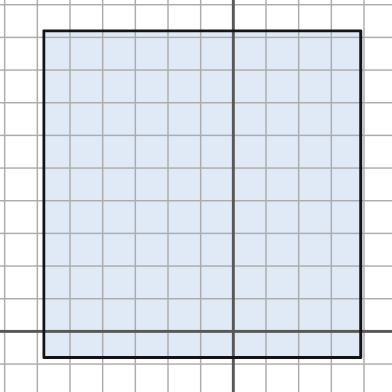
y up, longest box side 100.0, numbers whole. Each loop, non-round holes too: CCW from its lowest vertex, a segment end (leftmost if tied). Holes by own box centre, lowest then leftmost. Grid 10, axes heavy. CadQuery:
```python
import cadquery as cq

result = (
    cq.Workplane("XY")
    .moveTo(-58.0, -8.0)
    .lineTo(39.0, -8.0)
    .lineTo(39.0, 92.0)
    .lineTo(-58.0, 92.0)
    .close()
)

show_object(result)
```